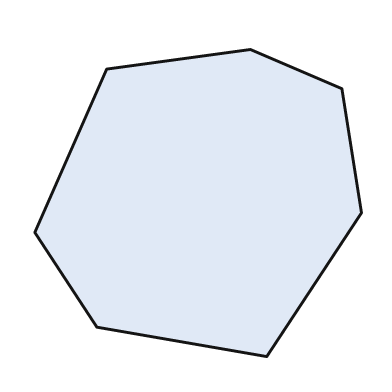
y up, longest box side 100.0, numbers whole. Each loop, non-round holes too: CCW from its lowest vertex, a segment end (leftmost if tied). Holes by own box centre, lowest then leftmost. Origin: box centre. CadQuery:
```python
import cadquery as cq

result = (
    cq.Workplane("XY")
    .moveTo(21.0, -47.0)
    .lineTo(50.0, -3.0)
    .lineTo(44.0, 35.0)
    .lineTo(16.0, 47.0)
    .lineTo(-28.0, 41.0)
    .lineTo(-50.0, -9.0)
    .lineTo(-31.0, -38.0)
    .close()
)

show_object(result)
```